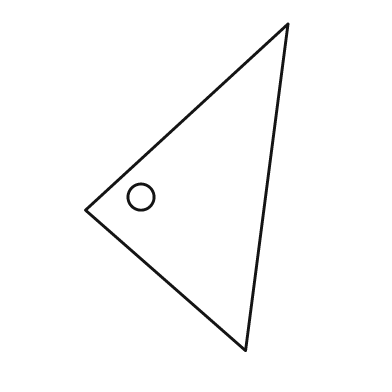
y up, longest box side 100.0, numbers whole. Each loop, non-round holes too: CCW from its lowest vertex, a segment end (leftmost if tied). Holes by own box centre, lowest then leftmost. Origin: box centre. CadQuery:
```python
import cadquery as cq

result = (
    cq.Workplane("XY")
    .moveTo(18.0, -50.0)
    .lineTo(31.0, 50.0)
    .lineTo(-31.0, -7.0)
    .close()
    .moveTo(-14.0, -3.0)
    .circle(4.0)
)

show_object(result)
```